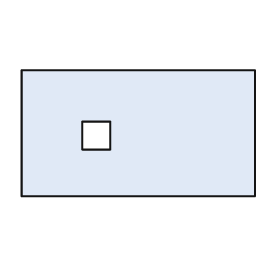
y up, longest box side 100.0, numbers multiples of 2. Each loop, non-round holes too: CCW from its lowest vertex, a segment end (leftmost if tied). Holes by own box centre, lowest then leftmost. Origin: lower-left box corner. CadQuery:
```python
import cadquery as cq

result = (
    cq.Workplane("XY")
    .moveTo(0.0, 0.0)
    .lineTo(100.0, 0.0)
    .lineTo(100.0, 54.0)
    .lineTo(0.0, 54.0)
    .close()
    .moveTo(26.0, 20.0)
    .lineTo(38.0, 20.0)
    .lineTo(38.0, 32.0)
    .lineTo(26.0, 32.0)
    .close()
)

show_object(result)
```